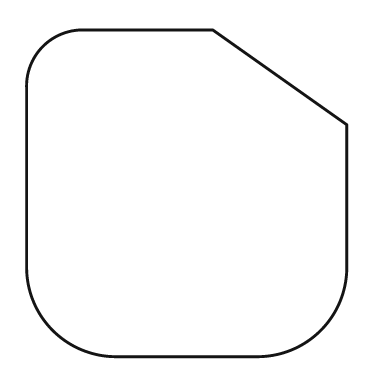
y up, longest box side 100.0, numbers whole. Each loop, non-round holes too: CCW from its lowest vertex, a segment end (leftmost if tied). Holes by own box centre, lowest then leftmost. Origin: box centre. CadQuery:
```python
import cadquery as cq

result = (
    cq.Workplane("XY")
    .moveTo(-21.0, -50.0)
    .lineTo(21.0, -50.0)
    .threePointArc((41.0, -42.0), (49.0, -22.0))
    .lineTo(49.0, 21.0)
    .lineTo(8.0, 50.0)
    .lineTo(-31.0, 50.0)
    .threePointArc((-44.0, 45.0), (-49.0, 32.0))
    .lineTo(-49.0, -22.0)
    .threePointArc((-41.0, -42.0), (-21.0, -50.0))
    .close()
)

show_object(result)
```